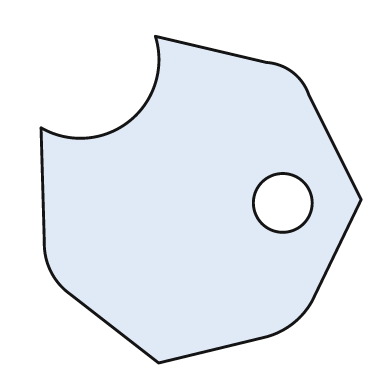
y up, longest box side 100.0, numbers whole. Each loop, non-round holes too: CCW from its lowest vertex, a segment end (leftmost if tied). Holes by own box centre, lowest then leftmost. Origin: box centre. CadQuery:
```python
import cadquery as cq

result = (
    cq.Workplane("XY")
    .moveTo(-13.0, -50.0)
    .lineTo(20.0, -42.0)
    .threePointArc((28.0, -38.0), (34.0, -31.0))
    .lineTo(49.0, 0.0)
    .lineTo(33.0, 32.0)
    .threePointArc((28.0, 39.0), (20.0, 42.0))
    .lineTo(-14.0, 50.0)
    .threePointArc((-22.0, 24.0), (-49.0, 22.0))
    .lineTo(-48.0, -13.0)
    .threePointArc((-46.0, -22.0), (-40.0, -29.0))
    .close()
    .moveTo(25.0, -1.0)
    .circle(9.0)
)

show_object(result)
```